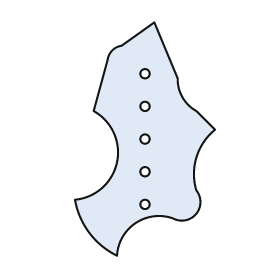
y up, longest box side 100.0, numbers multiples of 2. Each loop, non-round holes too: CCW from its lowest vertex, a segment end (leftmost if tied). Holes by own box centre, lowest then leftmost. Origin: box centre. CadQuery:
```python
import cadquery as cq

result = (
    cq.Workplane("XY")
    .moveTo(-12.0, -50.0)
    .threePointArc((-4.0, -36.0), (12.0, -34.0))
    .threePointArc((22.0, -32.0), (22.0, -22.0))
    .threePointArc((22.0, -8.0), (30.0, 4.0))
    .lineTo(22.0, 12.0)
    .threePointArc((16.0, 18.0), (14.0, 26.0))
    .lineTo(4.0, 50.0)
    .lineTo(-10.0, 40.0)
    .threePointArc((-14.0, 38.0), (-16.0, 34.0))
    .lineTo(-22.0, 12.0)
    .threePointArc((-12.0, -10.0), (-30.0, -26.0))
    .threePointArc((-24.0, -40.0), (-12.0, -50.0))
    .close()
    .moveTo(0.0, -28.0)
    .circle(2.0)
    .moveTo(0.0, -14.0)
    .circle(2.0)
    .moveTo(0.0, 0.0)
    .circle(2.0)
    .moveTo(0.0, 14.0)
    .circle(2.0)
    .moveTo(0.0, 28.0)
    .circle(2.0)
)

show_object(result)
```